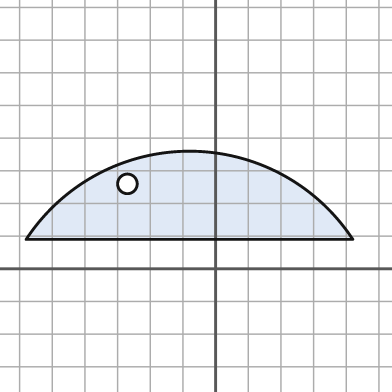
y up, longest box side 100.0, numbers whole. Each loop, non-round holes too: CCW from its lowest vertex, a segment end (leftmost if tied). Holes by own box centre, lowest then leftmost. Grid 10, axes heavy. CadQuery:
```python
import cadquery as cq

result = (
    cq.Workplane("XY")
    .moveTo(-58.0, 9.0)
    .lineTo(42.0, 9.0)
    .threePointArc((-8.0, 36.0), (-58.0, 9.0))
    .close()
    .moveTo(-27.0, 26.0)
    .circle(3.0)
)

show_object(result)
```